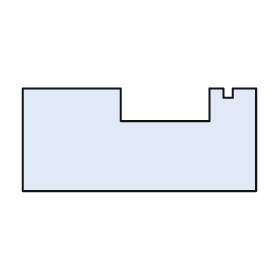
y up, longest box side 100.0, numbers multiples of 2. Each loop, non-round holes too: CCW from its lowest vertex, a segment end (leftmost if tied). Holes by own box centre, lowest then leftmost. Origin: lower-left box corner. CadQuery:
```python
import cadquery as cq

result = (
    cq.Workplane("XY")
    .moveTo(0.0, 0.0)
    .lineTo(100.0, 0.0)
    .lineTo(100.0, 44.0)
    .lineTo(90.0, 44.0)
    .lineTo(90.0, 40.0)
    .lineTo(86.0, 40.0)
    .lineTo(86.0, 44.0)
    .lineTo(80.0, 44.0)
    .lineTo(80.0, 30.0)
    .lineTo(42.0, 30.0)
    .lineTo(42.0, 44.0)
    .lineTo(0.0, 44.0)
    .close()
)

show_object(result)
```